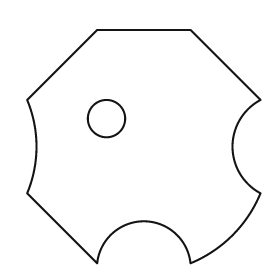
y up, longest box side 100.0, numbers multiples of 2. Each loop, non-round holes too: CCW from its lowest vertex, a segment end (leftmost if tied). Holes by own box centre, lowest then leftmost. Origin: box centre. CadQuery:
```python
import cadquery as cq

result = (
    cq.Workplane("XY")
    .moveTo(-20.0, -50.0)
    .threePointArc((0.0, -32.0), (20.0, -50.0))
    .threePointArc((38.0, -38.0), (50.0, -20.0))
    .threePointArc((38.0, 0.0), (50.0, 20.0))
    .lineTo(20.0, 50.0)
    .lineTo(-20.0, 50.0)
    .lineTo(-50.0, 20.0)
    .threePointArc((-46.0, 0.0), (-50.0, -20.0))
    .close()
    .moveTo(-16.0, 12.0)
    .circle(8.0)
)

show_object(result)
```